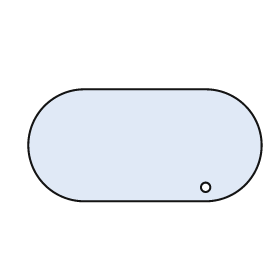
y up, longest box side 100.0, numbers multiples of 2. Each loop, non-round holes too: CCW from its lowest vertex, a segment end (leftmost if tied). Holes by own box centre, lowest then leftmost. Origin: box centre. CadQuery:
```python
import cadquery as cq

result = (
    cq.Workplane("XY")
    .moveTo(-26.0, -24.0)
    .lineTo(26.0, -24.0)
    .threePointArc((50.0, 0.0), (26.0, 24.0))
    .lineTo(-26.0, 24.0)
    .threePointArc((-50.0, 0.0), (-26.0, -24.0))
    .close()
    .moveTo(26.0, -18.0)
    .circle(2.0)
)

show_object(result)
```